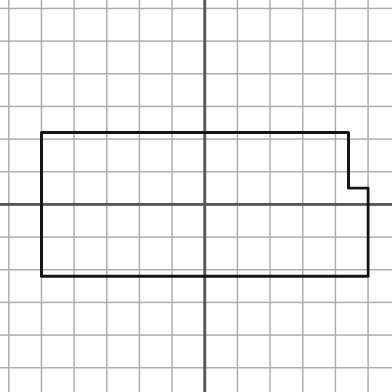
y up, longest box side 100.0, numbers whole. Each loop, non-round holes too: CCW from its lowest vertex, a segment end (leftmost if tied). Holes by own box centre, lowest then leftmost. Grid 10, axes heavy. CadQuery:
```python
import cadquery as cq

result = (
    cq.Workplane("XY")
    .moveTo(-50.0, -22.0)
    .lineTo(50.0, -22.0)
    .lineTo(50.0, 5.0)
    .lineTo(44.0, 5.0)
    .lineTo(44.0, 22.0)
    .lineTo(-50.0, 22.0)
    .close()
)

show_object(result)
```